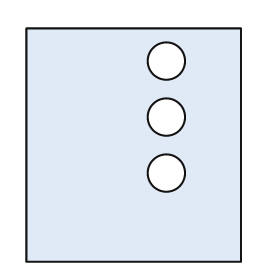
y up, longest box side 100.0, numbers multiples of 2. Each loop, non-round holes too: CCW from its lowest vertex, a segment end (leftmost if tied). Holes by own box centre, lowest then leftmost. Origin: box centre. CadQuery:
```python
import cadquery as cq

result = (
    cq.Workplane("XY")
    .moveTo(-46.0, -50.0)
    .lineTo(46.0, -50.0)
    .lineTo(46.0, 50.0)
    .lineTo(-46.0, 50.0)
    .close()
    .moveTo(14.0, -12.0)
    .circle(8.0)
    .moveTo(14.0, 12.0)
    .circle(8.0)
    .moveTo(14.0, 36.0)
    .circle(8.0)
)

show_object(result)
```